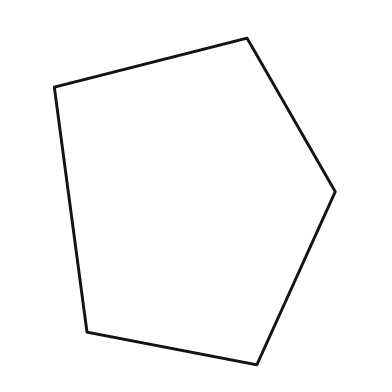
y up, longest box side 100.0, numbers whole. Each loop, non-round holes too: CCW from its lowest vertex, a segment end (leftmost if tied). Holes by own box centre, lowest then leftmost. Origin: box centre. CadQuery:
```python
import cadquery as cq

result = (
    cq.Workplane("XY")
    .moveTo(19.0, -50.0)
    .lineTo(43.0, 3.0)
    .lineTo(16.0, 50.0)
    .lineTo(-43.0, 35.0)
    .lineTo(-33.0, -40.0)
    .close()
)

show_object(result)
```